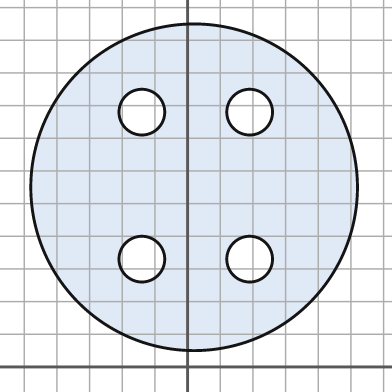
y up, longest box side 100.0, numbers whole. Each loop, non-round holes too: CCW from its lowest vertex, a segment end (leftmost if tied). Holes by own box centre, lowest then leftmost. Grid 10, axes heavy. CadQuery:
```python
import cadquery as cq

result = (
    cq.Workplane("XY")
    .moveTo(2.0, 55.0)
    .circle(50.0)
    .moveTo(-14.0, 33.0)
    .circle(7.0)
    .moveTo(19.0, 33.0)
    .circle(7.0)
    .moveTo(-14.0, 78.0)
    .circle(7.0)
    .moveTo(19.0, 78.0)
    .circle(7.0)
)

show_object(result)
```